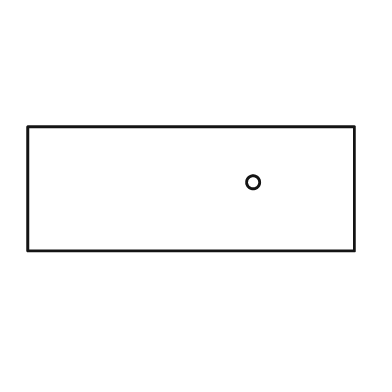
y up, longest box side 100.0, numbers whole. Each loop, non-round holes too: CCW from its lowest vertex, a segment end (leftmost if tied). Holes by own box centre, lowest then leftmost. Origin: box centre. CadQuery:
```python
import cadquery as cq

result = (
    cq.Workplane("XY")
    .moveTo(-50.0, -19.0)
    .lineTo(50.0, -19.0)
    .lineTo(50.0, 19.0)
    .lineTo(-50.0, 19.0)
    .close()
    .moveTo(19.0, 2.0)
    .circle(2.0)
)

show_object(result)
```